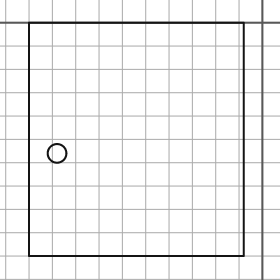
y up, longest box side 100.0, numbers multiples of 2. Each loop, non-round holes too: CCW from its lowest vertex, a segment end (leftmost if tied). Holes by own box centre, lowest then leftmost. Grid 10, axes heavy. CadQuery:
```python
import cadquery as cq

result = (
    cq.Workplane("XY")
    .moveTo(-100.0, -100.0)
    .lineTo(-8.0, -100.0)
    .lineTo(-8.0, 0.0)
    .lineTo(-100.0, 0.0)
    .close()
    .moveTo(-88.0, -56.0)
    .circle(4.0)
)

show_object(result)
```